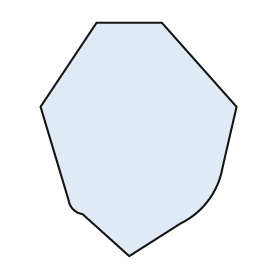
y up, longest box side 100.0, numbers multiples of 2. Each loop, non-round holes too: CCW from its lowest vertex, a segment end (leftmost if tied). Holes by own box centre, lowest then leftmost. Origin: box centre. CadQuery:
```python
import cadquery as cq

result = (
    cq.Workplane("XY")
    .moveTo(-4.0, -50.0)
    .lineTo(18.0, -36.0)
    .threePointArc((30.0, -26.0), (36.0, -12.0))
    .lineTo(42.0, 14.0)
    .lineTo(10.0, 50.0)
    .lineTo(-18.0, 50.0)
    .lineTo(-42.0, 14.0)
    .lineTo(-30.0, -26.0)
    .threePointArc((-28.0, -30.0), (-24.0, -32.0))
    .close()
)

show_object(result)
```